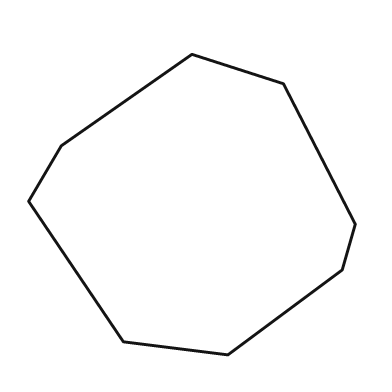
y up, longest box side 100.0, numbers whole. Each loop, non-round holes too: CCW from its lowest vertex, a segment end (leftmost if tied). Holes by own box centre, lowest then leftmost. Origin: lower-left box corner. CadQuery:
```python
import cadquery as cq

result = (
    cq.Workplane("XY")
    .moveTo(61.0, 0.0)
    .lineTo(96.0, 26.0)
    .lineTo(100.0, 40.0)
    .lineTo(78.0, 83.0)
    .lineTo(50.0, 92.0)
    .lineTo(10.0, 64.0)
    .lineTo(0.0, 47.0)
    .lineTo(29.0, 4.0)
    .close()
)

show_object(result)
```